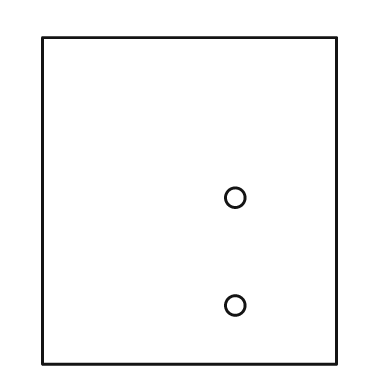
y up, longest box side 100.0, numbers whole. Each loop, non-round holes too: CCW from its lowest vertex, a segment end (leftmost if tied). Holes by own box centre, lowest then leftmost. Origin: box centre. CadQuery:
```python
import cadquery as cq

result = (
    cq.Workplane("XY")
    .moveTo(-45.0, -50.0)
    .lineTo(45.0, -50.0)
    .lineTo(45.0, 50.0)
    .lineTo(-45.0, 50.0)
    .close()
    .moveTo(14.0, -32.0)
    .circle(3.0)
    .moveTo(14.0, 1.0)
    .circle(3.0)
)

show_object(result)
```